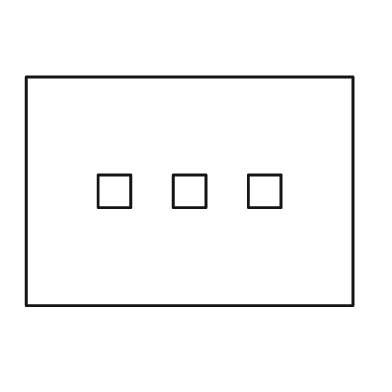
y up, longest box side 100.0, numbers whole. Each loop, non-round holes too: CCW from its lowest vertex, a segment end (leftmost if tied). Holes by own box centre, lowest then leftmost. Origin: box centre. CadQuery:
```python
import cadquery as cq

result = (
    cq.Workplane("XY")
    .moveTo(-50.0, -35.0)
    .lineTo(50.0, -35.0)
    .lineTo(50.0, 35.0)
    .lineTo(-50.0, 35.0)
    .close()
    .moveTo(-28.0, -5.0)
    .lineTo(-18.0, -5.0)
    .lineTo(-18.0, 5.0)
    .lineTo(-28.0, 5.0)
    .close()
    .moveTo(-5.0, -5.0)
    .lineTo(5.0, -5.0)
    .lineTo(5.0, 5.0)
    .lineTo(-5.0, 5.0)
    .close()
    .moveTo(18.0, -5.0)
    .lineTo(28.0, -5.0)
    .lineTo(28.0, 5.0)
    .lineTo(18.0, 5.0)
    .close()
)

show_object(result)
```